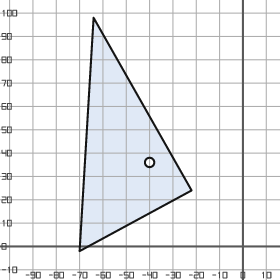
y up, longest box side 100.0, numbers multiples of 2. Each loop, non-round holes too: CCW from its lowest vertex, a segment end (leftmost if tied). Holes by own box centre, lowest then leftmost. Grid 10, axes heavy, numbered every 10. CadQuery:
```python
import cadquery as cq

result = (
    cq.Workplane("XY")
    .moveTo(-70.0, -2.0)
    .lineTo(-22.0, 24.0)
    .lineTo(-64.0, 98.0)
    .close()
    .moveTo(-40.0, 36.0)
    .circle(2.0)
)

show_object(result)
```